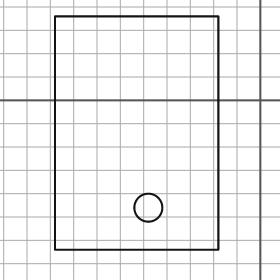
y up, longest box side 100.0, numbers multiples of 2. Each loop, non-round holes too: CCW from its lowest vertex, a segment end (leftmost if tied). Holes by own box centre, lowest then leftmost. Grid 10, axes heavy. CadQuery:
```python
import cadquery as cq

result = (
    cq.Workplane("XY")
    .moveTo(-88.0, -64.0)
    .lineTo(-18.0, -64.0)
    .lineTo(-18.0, 36.0)
    .lineTo(-88.0, 36.0)
    .close()
    .moveTo(-48.0, -46.0)
    .circle(6.0)
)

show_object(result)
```